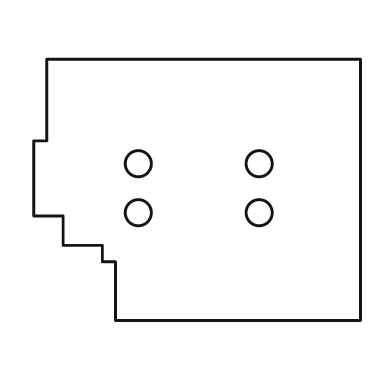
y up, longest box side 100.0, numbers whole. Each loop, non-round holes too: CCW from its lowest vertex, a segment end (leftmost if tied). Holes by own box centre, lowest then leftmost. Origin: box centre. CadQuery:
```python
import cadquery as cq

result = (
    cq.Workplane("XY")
    .moveTo(-25.0, -40.0)
    .lineTo(50.0, -40.0)
    .lineTo(50.0, 40.0)
    .lineTo(-46.0, 40.0)
    .lineTo(-46.0, 15.0)
    .lineTo(-50.0, 15.0)
    .lineTo(-50.0, -8.0)
    .lineTo(-41.0, -8.0)
    .lineTo(-41.0, -17.0)
    .lineTo(-29.0, -17.0)
    .lineTo(-29.0, -22.0)
    .lineTo(-25.0, -22.0)
    .close()
    .moveTo(-18.0, -7.0)
    .circle(4.0)
    .moveTo(19.0, -7.0)
    .circle(4.0)
    .moveTo(-18.0, 8.0)
    .circle(4.0)
    .moveTo(19.0, 8.0)
    .circle(4.0)
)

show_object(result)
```